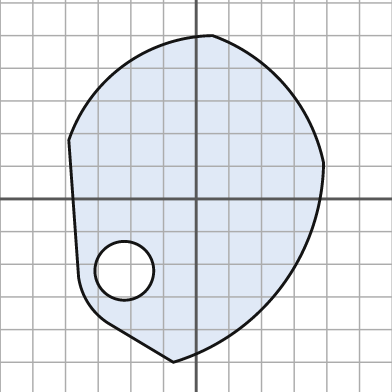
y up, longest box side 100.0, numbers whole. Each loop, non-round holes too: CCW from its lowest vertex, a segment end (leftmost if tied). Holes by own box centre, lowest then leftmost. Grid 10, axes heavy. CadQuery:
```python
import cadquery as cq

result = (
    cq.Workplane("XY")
    .moveTo(-7.0, -50.0)
    .threePointArc((26.0, -27.0), (39.0, 11.0))
    .threePointArc((27.0, 35.0), (5.0, 50.0))
    .threePointArc((-22.0, 41.0), (-39.0, 18.0))
    .lineTo(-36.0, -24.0)
    .threePointArc((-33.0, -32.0), (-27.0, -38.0))
    .close()
    .moveTo(-22.0, -22.0)
    .circle(9.0)
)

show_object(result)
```